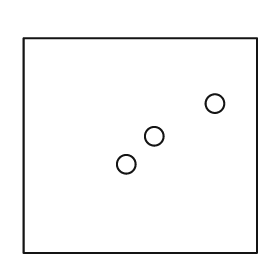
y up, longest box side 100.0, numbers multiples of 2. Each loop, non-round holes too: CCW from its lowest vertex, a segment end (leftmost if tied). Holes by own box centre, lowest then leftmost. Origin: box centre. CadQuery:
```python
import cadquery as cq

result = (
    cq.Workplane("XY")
    .moveTo(-50.0, -46.0)
    .lineTo(50.0, -46.0)
    .lineTo(50.0, 46.0)
    .lineTo(-50.0, 46.0)
    .close()
    .moveTo(-6.0, -8.0)
    .circle(4.0)
    .moveTo(6.0, 4.0)
    .circle(4.0)
    .moveTo(32.0, 18.0)
    .circle(4.0)
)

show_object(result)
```